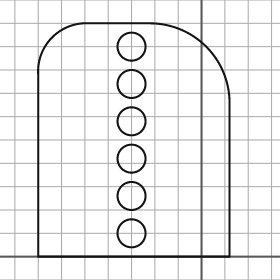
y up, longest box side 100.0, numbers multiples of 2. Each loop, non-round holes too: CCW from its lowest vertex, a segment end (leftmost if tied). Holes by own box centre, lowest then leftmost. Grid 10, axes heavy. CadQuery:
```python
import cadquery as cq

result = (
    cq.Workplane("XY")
    .moveTo(-70.0, 0.0)
    .lineTo(12.0, 0.0)
    .lineTo(12.0, 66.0)
    .threePointArc((2.0, 90.0), (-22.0, 100.0))
    .lineTo(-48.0, 100.0)
    .threePointArc((-64.0, 94.0), (-70.0, 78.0))
    .close()
    .moveTo(-30.0, 10.0)
    .circle(6.0)
    .moveTo(-30.0, 26.0)
    .circle(6.0)
    .moveTo(-30.0, 42.0)
    .circle(6.0)
    .moveTo(-30.0, 58.0)
    .circle(6.0)
    .moveTo(-30.0, 74.0)
    .circle(6.0)
    .moveTo(-30.0, 90.0)
    .circle(6.0)
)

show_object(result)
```